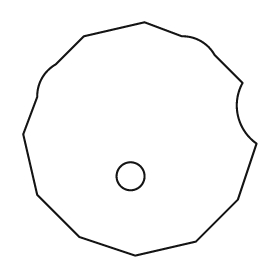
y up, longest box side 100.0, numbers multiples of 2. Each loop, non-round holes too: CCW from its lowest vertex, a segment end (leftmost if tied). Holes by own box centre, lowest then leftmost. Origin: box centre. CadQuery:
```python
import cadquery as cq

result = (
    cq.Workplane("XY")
    .moveTo(-2.0, -50.0)
    .lineTo(24.0, -44.0)
    .lineTo(42.0, -26.0)
    .lineTo(50.0, -2.0)
    .threePointArc((42.0, 10.0), (44.0, 24.0))
    .lineTo(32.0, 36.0)
    .threePointArc((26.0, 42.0), (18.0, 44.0))
    .lineTo(2.0, 50.0)
    .lineTo(-24.0, 44.0)
    .lineTo(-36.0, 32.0)
    .threePointArc((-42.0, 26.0), (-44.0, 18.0))
    .lineTo(-50.0, 2.0)
    .lineTo(-44.0, -24.0)
    .lineTo(-26.0, -42.0)
    .close()
    .moveTo(-4.0, -16.0)
    .circle(6.0)
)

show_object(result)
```